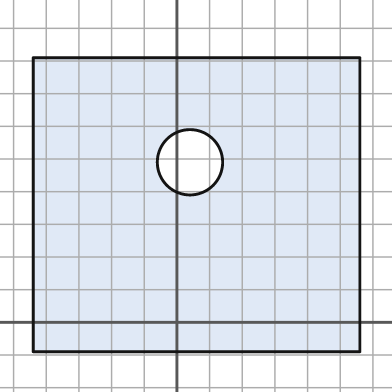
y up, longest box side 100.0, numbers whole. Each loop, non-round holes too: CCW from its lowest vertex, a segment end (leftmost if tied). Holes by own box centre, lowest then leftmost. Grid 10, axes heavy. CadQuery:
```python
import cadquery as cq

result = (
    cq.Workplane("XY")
    .moveTo(-44.0, -9.0)
    .lineTo(56.0, -9.0)
    .lineTo(56.0, 81.0)
    .lineTo(-44.0, 81.0)
    .close()
    .moveTo(4.0, 49.0)
    .circle(10.0)
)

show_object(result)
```